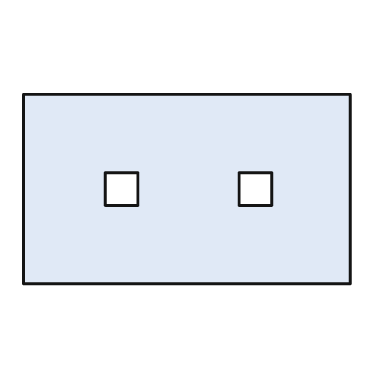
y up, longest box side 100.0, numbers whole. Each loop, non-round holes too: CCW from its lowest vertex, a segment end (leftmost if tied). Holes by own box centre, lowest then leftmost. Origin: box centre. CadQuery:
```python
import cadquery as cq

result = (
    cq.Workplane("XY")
    .moveTo(-50.0, -29.0)
    .lineTo(50.0, -29.0)
    .lineTo(50.0, 29.0)
    .lineTo(-50.0, 29.0)
    .close()
    .moveTo(-25.0, -5.0)
    .lineTo(-15.0, -5.0)
    .lineTo(-15.0, 5.0)
    .lineTo(-25.0, 5.0)
    .close()
    .moveTo(16.0, -5.0)
    .lineTo(26.0, -5.0)
    .lineTo(26.0, 5.0)
    .lineTo(16.0, 5.0)
    .close()
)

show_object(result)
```